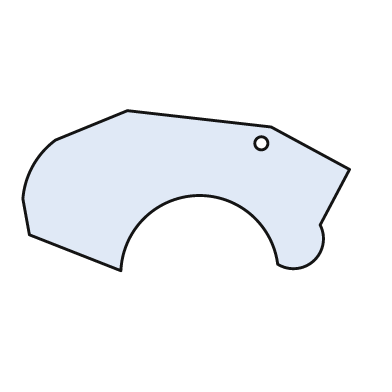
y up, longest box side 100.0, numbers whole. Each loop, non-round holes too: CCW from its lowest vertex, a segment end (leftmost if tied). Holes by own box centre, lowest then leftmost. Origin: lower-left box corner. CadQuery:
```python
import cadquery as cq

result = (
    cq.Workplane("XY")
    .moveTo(30.0, 0.0)
    .threePointArc((53.0, 23.0), (78.0, 2.0))
    .threePointArc((89.0, 3.0), (91.0, 14.0))
    .lineTo(100.0, 31.0)
    .lineTo(76.0, 44.0)
    .lineTo(32.0, 49.0)
    .lineTo(10.0, 40.0)
    .threePointArc((3.0, 32.0), (0.0, 22.0))
    .lineTo(2.0, 11.0)
    .close()
    .moveTo(73.0, 39.0)
    .circle(2.0)
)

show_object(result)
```